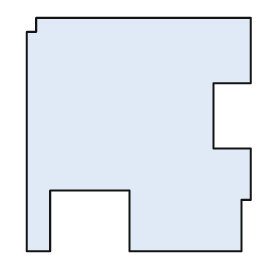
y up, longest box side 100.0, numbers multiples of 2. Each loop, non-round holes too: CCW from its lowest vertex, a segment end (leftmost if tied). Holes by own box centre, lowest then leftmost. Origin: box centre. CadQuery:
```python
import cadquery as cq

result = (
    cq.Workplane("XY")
    .moveTo(-48.0, -50.0)
    .lineTo(-38.0, -50.0)
    .lineTo(-38.0, -24.0)
    .lineTo(-4.0, -24.0)
    .lineTo(-4.0, -50.0)
    .lineTo(44.0, -50.0)
    .lineTo(44.0, -28.0)
    .lineTo(48.0, -28.0)
    .lineTo(48.0, -6.0)
    .lineTo(32.0, -6.0)
    .lineTo(32.0, 22.0)
    .lineTo(48.0, 22.0)
    .lineTo(48.0, 50.0)
    .lineTo(-44.0, 50.0)
    .lineTo(-44.0, 44.0)
    .lineTo(-48.0, 44.0)
    .close()
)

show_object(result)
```